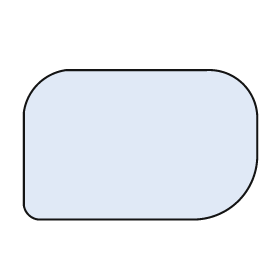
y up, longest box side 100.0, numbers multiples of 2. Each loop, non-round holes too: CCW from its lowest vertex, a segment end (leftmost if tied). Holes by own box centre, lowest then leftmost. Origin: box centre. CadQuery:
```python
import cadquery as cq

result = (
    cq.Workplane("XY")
    .moveTo(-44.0, -32.0)
    .lineTo(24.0, -32.0)
    .threePointArc((42.0, -24.0), (50.0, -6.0))
    .lineTo(50.0, 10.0)
    .threePointArc((44.0, 26.0), (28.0, 32.0))
    .lineTo(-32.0, 32.0)
    .threePointArc((-44.0, 26.0), (-50.0, 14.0))
    .lineTo(-50.0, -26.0)
    .threePointArc((-48.0, -30.0), (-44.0, -32.0))
    .close()
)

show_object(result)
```